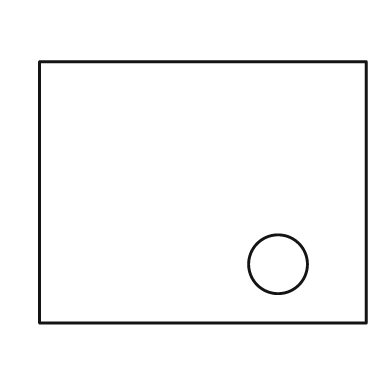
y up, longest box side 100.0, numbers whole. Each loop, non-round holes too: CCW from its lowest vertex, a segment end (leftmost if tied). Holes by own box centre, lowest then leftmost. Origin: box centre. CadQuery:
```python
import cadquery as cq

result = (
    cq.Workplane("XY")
    .moveTo(-50.0, -40.0)
    .lineTo(50.0, -40.0)
    .lineTo(50.0, 40.0)
    .lineTo(-50.0, 40.0)
    .close()
    .moveTo(23.0, -22.0)
    .circle(9.0)
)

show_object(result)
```